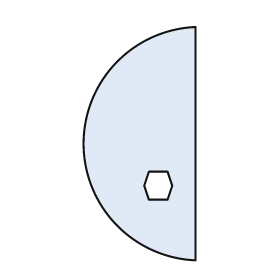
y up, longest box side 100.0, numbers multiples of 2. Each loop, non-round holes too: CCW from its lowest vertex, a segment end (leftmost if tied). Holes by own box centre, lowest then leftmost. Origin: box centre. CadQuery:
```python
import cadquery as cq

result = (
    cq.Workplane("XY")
    .moveTo(24.0, -50.0)
    .lineTo(24.0, 50.0)
    .threePointArc((-24.0, 0.0), (24.0, -50.0))
    .close()
    .moveTo(4.0, -24.0)
    .lineTo(12.0, -24.0)
    .lineTo(14.0, -18.0)
    .lineTo(12.0, -12.0)
    .lineTo(4.0, -12.0)
    .lineTo(2.0, -18.0)
    .close()
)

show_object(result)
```